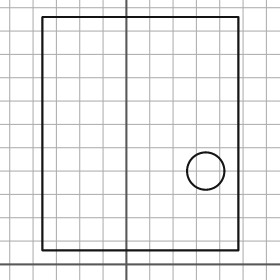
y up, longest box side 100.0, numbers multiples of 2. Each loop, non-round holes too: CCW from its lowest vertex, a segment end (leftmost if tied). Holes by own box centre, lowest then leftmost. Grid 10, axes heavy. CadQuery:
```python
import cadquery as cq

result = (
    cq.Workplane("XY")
    .moveTo(-36.0, 6.0)
    .lineTo(48.0, 6.0)
    .lineTo(48.0, 106.0)
    .lineTo(-36.0, 106.0)
    .close()
    .moveTo(34.0, 40.0)
    .circle(8.0)
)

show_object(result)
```